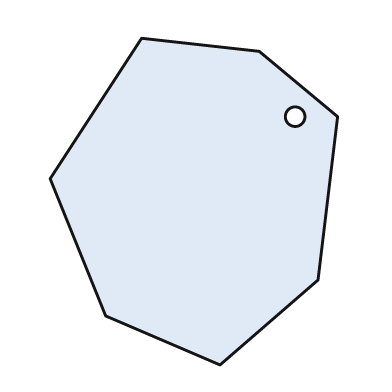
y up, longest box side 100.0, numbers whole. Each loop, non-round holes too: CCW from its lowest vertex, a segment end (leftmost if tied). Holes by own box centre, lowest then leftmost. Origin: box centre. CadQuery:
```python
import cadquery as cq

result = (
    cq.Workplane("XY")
    .moveTo(8.0, -50.0)
    .lineTo(38.0, -24.0)
    .lineTo(44.0, 26.0)
    .lineTo(20.0, 46.0)
    .lineTo(-16.0, 50.0)
    .lineTo(-44.0, 7.0)
    .lineTo(-27.0, -35.0)
    .close()
    .moveTo(31.0, 26.0)
    .circle(3.0)
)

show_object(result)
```